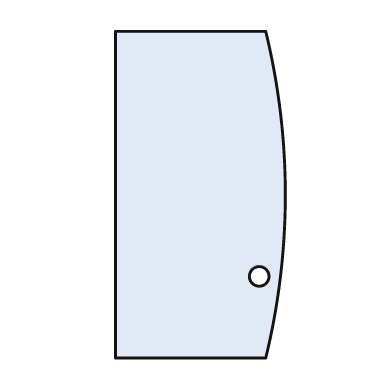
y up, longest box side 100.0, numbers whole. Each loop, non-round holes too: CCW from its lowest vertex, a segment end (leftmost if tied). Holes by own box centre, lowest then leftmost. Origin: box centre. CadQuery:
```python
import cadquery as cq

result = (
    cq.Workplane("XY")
    .moveTo(-26.0, -50.0)
    .lineTo(20.0, -50.0)
    .threePointArc((26.0, 0.0), (20.0, 50.0))
    .lineTo(-26.0, 50.0)
    .close()
    .moveTo(18.0, -25.0)
    .circle(3.0)
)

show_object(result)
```